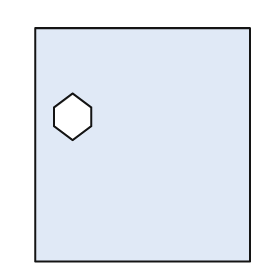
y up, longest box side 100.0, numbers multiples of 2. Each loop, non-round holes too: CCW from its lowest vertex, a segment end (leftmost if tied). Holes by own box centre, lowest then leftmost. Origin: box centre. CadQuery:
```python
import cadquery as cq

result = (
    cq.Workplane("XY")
    .moveTo(-46.0, -50.0)
    .lineTo(46.0, -50.0)
    .lineTo(46.0, 50.0)
    .lineTo(-46.0, 50.0)
    .close()
    .moveTo(-30.0, 2.0)
    .lineTo(-22.0, 8.0)
    .lineTo(-22.0, 16.0)
    .lineTo(-30.0, 22.0)
    .lineTo(-38.0, 16.0)
    .lineTo(-38.0, 8.0)
    .close()
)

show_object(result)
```